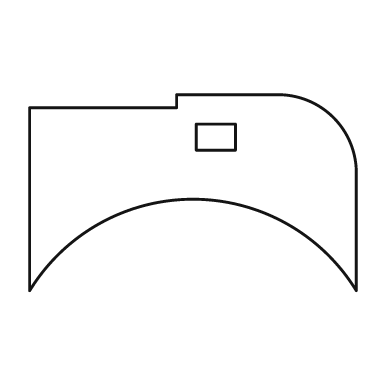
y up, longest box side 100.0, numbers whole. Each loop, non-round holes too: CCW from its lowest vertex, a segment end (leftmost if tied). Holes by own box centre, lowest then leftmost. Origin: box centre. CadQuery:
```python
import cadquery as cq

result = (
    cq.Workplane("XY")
    .moveTo(-50.0, -30.0)
    .threePointArc((0.0, -2.0), (50.0, -30.0))
    .lineTo(50.0, 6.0)
    .threePointArc((43.0, 23.0), (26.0, 30.0))
    .lineTo(-5.0, 30.0)
    .lineTo(-5.0, 26.0)
    .lineTo(-50.0, 26.0)
    .close()
    .moveTo(1.0, 13.0)
    .lineTo(13.0, 13.0)
    .lineTo(13.0, 21.0)
    .lineTo(1.0, 21.0)
    .close()
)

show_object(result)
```